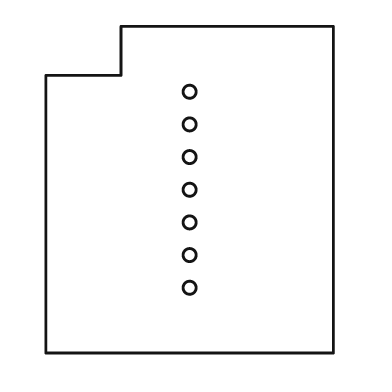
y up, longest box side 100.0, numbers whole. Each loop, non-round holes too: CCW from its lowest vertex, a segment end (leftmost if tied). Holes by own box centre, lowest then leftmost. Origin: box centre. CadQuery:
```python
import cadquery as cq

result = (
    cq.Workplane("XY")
    .moveTo(-44.0, -50.0)
    .lineTo(44.0, -50.0)
    .lineTo(44.0, 50.0)
    .lineTo(-21.0, 50.0)
    .lineTo(-21.0, 35.0)
    .lineTo(-44.0, 35.0)
    .close()
    .moveTo(0.0, -30.0)
    .circle(2.0)
    .moveTo(0.0, -20.0)
    .circle(2.0)
    .moveTo(0.0, -10.0)
    .circle(2.0)
    .moveTo(0.0, 0.0)
    .circle(2.0)
    .moveTo(0.0, 10.0)
    .circle(2.0)
    .moveTo(0.0, 20.0)
    .circle(2.0)
    .moveTo(0.0, 30.0)
    .circle(2.0)
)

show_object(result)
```